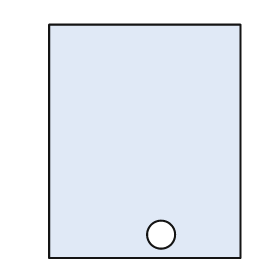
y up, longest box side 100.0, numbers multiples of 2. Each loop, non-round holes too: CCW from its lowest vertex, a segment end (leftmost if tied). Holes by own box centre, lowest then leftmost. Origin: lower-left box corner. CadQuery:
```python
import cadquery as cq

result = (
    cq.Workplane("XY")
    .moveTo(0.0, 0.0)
    .lineTo(82.0, 0.0)
    .lineTo(82.0, 100.0)
    .lineTo(0.0, 100.0)
    .close()
    .moveTo(48.0, 10.0)
    .circle(6.0)
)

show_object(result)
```